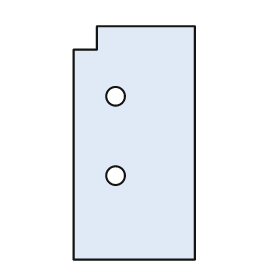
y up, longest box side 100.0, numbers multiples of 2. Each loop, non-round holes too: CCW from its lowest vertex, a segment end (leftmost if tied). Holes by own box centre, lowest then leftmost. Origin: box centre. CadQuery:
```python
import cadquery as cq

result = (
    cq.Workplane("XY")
    .moveTo(-26.0, -50.0)
    .lineTo(26.0, -50.0)
    .lineTo(26.0, 50.0)
    .lineTo(-16.0, 50.0)
    .lineTo(-16.0, 40.0)
    .lineTo(-26.0, 40.0)
    .close()
    .moveTo(-8.0, -14.0)
    .circle(4.0)
    .moveTo(-8.0, 20.0)
    .circle(4.0)
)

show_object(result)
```